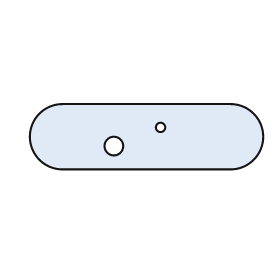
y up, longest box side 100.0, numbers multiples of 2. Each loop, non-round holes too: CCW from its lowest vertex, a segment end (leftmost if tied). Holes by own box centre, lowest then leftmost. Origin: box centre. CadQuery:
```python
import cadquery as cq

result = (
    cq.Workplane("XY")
    .moveTo(-36.0, -14.0)
    .lineTo(36.0, -14.0)
    .threePointArc((50.0, 0.0), (36.0, 14.0))
    .lineTo(-36.0, 14.0)
    .threePointArc((-50.0, 0.0), (-36.0, -14.0))
    .close()
    .moveTo(-14.0, -4.0)
    .circle(4.0)
    .moveTo(6.0, 4.0)
    .circle(2.0)
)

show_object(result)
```